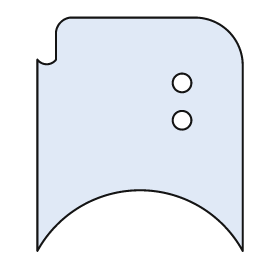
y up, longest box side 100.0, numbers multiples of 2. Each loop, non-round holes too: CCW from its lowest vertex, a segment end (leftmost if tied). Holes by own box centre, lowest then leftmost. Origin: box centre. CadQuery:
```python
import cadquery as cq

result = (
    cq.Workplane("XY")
    .moveTo(-44.0, -50.0)
    .threePointArc((0.0, -24.0), (44.0, -50.0))
    .lineTo(44.0, 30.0)
    .threePointArc((38.0, 44.0), (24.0, 50.0))
    .lineTo(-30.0, 50.0)
    .threePointArc((-34.0, 48.0), (-36.0, 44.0))
    .lineTo(-36.0, 32.0)
    .threePointArc((-40.0, 30.0), (-44.0, 32.0))
    .close()
    .moveTo(18.0, 6.0)
    .circle(4.0)
    .moveTo(18.0, 22.0)
    .circle(4.0)
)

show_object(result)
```